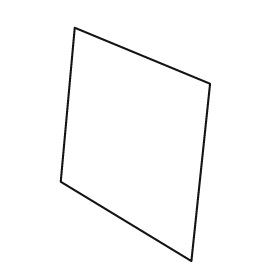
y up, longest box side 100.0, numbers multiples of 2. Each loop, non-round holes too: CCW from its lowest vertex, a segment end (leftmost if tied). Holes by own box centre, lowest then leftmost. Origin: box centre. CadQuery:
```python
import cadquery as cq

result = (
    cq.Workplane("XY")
    .moveTo(24.0, -50.0)
    .lineTo(32.0, 26.0)
    .lineTo(-26.0, 50.0)
    .lineTo(-32.0, -16.0)
    .close()
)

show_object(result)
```